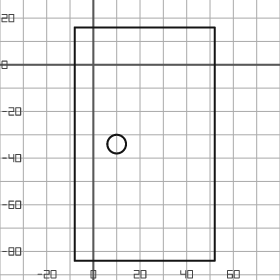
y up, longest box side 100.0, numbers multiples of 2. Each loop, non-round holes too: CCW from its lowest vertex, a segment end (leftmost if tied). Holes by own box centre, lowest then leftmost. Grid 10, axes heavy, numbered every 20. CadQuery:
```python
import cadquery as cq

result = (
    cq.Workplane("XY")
    .moveTo(-8.0, -84.0)
    .lineTo(52.0, -84.0)
    .lineTo(52.0, 16.0)
    .lineTo(-8.0, 16.0)
    .close()
    .moveTo(10.0, -34.0)
    .circle(4.0)
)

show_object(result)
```